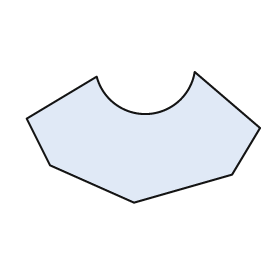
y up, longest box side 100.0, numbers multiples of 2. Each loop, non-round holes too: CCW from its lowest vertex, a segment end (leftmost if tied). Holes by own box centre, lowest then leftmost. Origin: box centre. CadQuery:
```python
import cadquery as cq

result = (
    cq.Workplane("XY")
    .moveTo(-4.0, -28.0)
    .lineTo(38.0, -16.0)
    .lineTo(50.0, 4.0)
    .lineTo(22.0, 28.0)
    .threePointArc((2.0, 10.0), (-20.0, 26.0))
    .lineTo(-50.0, 8.0)
    .lineTo(-40.0, -12.0)
    .close()
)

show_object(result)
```